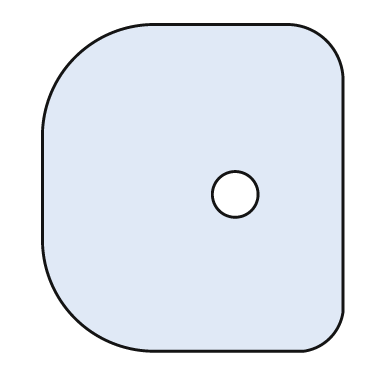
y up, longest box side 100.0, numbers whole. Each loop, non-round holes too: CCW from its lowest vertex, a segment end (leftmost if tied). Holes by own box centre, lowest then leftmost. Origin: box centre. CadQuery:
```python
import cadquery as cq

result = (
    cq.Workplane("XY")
    .moveTo(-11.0, -50.0)
    .lineTo(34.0, -50.0)
    .threePointArc((42.0, -46.0), (46.0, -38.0))
    .lineTo(46.0, 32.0)
    .threePointArc((41.0, 45.0), (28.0, 50.0))
    .lineTo(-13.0, 50.0)
    .threePointArc((-36.0, 40.0), (-46.0, 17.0))
    .lineTo(-46.0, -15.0)
    .threePointArc((-36.0, -40.0), (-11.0, -50.0))
    .close()
    .moveTo(13.0, -2.0)
    .circle(7.0)
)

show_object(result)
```